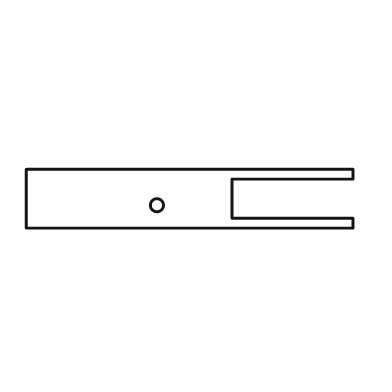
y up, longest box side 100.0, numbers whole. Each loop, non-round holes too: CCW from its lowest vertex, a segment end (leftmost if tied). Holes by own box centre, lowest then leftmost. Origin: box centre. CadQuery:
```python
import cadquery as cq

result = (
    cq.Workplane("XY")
    .moveTo(-50.0, -9.0)
    .lineTo(50.0, -9.0)
    .lineTo(50.0, -6.0)
    .lineTo(13.0, -6.0)
    .lineTo(13.0, 6.0)
    .lineTo(50.0, 6.0)
    .lineTo(50.0, 9.0)
    .lineTo(-50.0, 9.0)
    .close()
    .moveTo(-10.0, -2.0)
    .circle(2.0)
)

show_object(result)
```